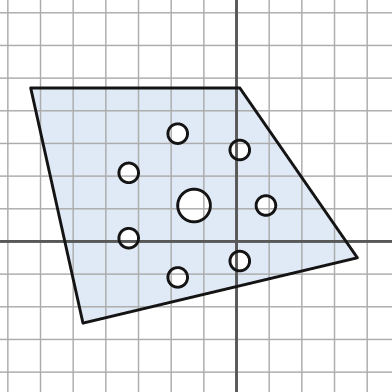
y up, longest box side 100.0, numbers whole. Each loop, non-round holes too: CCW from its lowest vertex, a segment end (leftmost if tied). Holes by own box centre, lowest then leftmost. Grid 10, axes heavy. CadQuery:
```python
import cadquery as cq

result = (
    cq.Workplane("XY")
    .moveTo(-47.0, -25.0)
    .lineTo(37.0, -5.0)
    .lineTo(1.0, 47.0)
    .lineTo(-63.0, 47.0)
    .close()
    .moveTo(-18.0, -11.0)
    .circle(3.0)
    .moveTo(1.0, -6.0)
    .circle(3.0)
    .moveTo(-33.0, 1.0)
    .circle(3.0)
    .moveTo(-13.0, 11.0)
    .circle(5.0)
    .moveTo(9.0, 11.0)
    .circle(3.0)
    .moveTo(-33.0, 21.0)
    .circle(3.0)
    .moveTo(1.0, 28.0)
    .circle(3.0)
    .moveTo(-18.0, 33.0)
    .circle(3.0)
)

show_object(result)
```